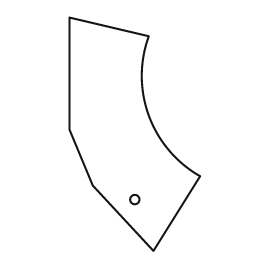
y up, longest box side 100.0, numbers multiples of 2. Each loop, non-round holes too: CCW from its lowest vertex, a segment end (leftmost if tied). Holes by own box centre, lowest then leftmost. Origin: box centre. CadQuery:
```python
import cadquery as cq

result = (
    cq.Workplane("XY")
    .moveTo(8.0, -50.0)
    .lineTo(28.0, -18.0)
    .threePointArc((6.0, 8.0), (6.0, 42.0))
    .lineTo(-28.0, 50.0)
    .lineTo(-28.0, 2.0)
    .lineTo(-18.0, -22.0)
    .close()
    .moveTo(0.0, -28.0)
    .circle(2.0)
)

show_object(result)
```